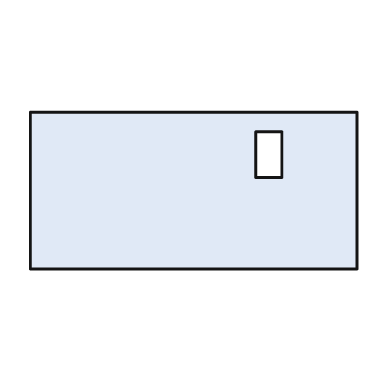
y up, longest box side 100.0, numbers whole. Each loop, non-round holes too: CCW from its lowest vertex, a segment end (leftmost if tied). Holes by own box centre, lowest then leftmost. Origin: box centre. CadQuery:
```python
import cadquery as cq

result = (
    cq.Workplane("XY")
    .moveTo(-50.0, -24.0)
    .lineTo(50.0, -24.0)
    .lineTo(50.0, 24.0)
    .lineTo(-50.0, 24.0)
    .close()
    .moveTo(19.0, 4.0)
    .lineTo(27.0, 4.0)
    .lineTo(27.0, 18.0)
    .lineTo(19.0, 18.0)
    .close()
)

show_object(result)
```